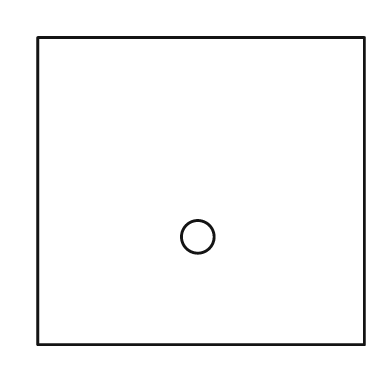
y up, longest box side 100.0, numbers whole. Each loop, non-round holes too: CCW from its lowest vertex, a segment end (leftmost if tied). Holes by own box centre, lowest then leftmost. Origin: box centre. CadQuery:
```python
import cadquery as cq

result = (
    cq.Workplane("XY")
    .moveTo(-50.0, -47.0)
    .lineTo(50.0, -47.0)
    .lineTo(50.0, 47.0)
    .lineTo(-50.0, 47.0)
    .close()
    .moveTo(-1.0, -14.0)
    .circle(5.0)
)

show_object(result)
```